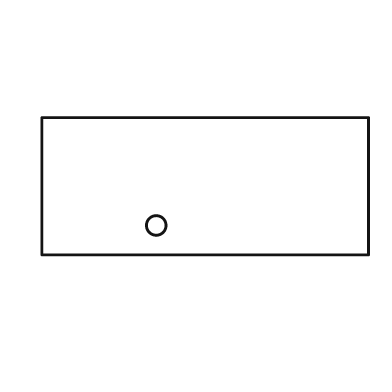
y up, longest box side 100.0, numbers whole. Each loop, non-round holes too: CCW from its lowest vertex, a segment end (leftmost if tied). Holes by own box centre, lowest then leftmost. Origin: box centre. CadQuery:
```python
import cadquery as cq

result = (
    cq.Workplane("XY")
    .moveTo(-50.0, -21.0)
    .lineTo(50.0, -21.0)
    .lineTo(50.0, 21.0)
    .lineTo(-50.0, 21.0)
    .close()
    .moveTo(-15.0, -12.0)
    .circle(3.0)
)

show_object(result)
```